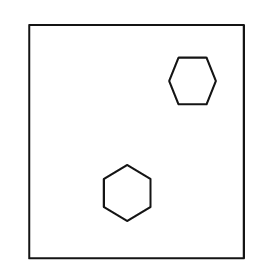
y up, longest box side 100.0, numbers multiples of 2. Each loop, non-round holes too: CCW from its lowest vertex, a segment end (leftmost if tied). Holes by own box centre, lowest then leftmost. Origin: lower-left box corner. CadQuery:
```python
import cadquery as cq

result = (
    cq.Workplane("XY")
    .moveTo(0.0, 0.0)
    .lineTo(92.0, 0.0)
    .lineTo(92.0, 100.0)
    .lineTo(0.0, 100.0)
    .close()
    .moveTo(42.0, 16.0)
    .lineTo(52.0, 22.0)
    .lineTo(52.0, 34.0)
    .lineTo(42.0, 40.0)
    .lineTo(32.0, 34.0)
    .lineTo(32.0, 22.0)
    .close()
    .moveTo(64.0, 66.0)
    .lineTo(76.0, 66.0)
    .lineTo(80.0, 76.0)
    .lineTo(76.0, 86.0)
    .lineTo(64.0, 86.0)
    .lineTo(60.0, 76.0)
    .close()
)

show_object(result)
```